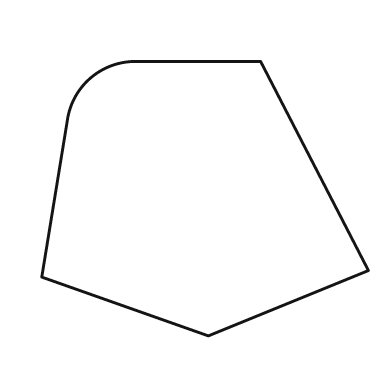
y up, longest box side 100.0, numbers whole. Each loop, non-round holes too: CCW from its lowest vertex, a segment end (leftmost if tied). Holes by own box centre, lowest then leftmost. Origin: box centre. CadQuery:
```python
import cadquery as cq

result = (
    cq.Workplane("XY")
    .moveTo(1.0, -42.0)
    .lineTo(50.0, -22.0)
    .lineTo(17.0, 42.0)
    .lineTo(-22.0, 42.0)
    .threePointArc((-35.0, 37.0), (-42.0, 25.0))
    .lineTo(-50.0, -24.0)
    .close()
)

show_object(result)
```